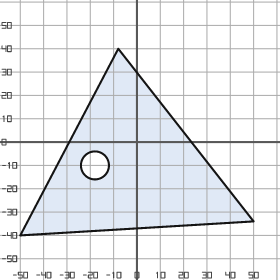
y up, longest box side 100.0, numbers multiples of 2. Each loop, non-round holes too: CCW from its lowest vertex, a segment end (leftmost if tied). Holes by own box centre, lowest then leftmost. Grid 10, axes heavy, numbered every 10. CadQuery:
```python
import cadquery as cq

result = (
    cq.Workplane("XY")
    .moveTo(-50.0, -40.0)
    .lineTo(50.0, -34.0)
    .lineTo(-8.0, 40.0)
    .close()
    .moveTo(-18.0, -10.0)
    .circle(6.0)
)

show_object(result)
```